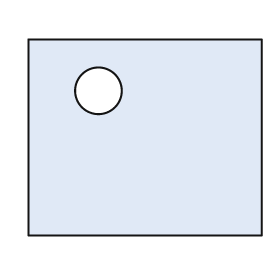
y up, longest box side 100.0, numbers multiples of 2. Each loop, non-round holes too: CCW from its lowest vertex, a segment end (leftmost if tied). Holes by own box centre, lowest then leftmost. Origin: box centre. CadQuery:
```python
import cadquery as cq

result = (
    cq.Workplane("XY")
    .moveTo(-50.0, -42.0)
    .lineTo(50.0, -42.0)
    .lineTo(50.0, 42.0)
    .lineTo(-50.0, 42.0)
    .close()
    .moveTo(-20.0, 20.0)
    .circle(10.0)
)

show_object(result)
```